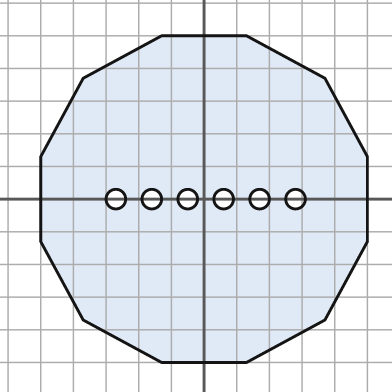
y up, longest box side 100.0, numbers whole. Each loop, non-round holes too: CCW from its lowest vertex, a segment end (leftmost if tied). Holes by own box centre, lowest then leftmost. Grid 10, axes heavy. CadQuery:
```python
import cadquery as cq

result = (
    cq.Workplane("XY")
    .moveTo(-13.0, -50.0)
    .lineTo(13.0, -50.0)
    .lineTo(37.0, -37.0)
    .lineTo(50.0, -13.0)
    .lineTo(50.0, 13.0)
    .lineTo(37.0, 37.0)
    .lineTo(13.0, 50.0)
    .lineTo(-13.0, 50.0)
    .lineTo(-37.0, 37.0)
    .lineTo(-50.0, 13.0)
    .lineTo(-50.0, -13.0)
    .lineTo(-37.0, -37.0)
    .close()
    .moveTo(-27.0, 0.0)
    .circle(3.0)
    .moveTo(-16.0, 0.0)
    .circle(3.0)
    .moveTo(-5.0, 0.0)
    .circle(3.0)
    .moveTo(6.0, 0.0)
    .circle(3.0)
    .moveTo(17.0, 0.0)
    .circle(3.0)
    .moveTo(28.0, 0.0)
    .circle(3.0)
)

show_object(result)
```